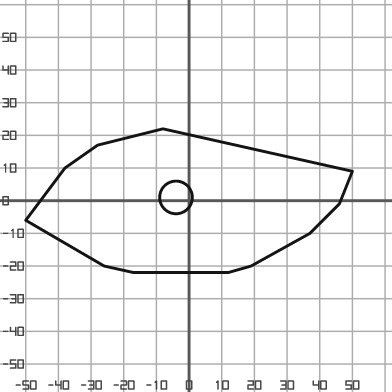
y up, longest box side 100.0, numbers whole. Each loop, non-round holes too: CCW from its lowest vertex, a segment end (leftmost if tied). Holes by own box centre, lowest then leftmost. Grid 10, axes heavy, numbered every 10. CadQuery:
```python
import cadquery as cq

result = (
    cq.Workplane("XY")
    .moveTo(-17.0, -22.0)
    .lineTo(12.0, -22.0)
    .lineTo(19.0, -20.0)
    .lineTo(37.0, -10.0)
    .lineTo(46.0, -1.0)
    .lineTo(50.0, 9.0)
    .lineTo(-8.0, 22.0)
    .lineTo(-28.0, 17.0)
    .lineTo(-38.0, 10.0)
    .lineTo(-50.0, -6.0)
    .lineTo(-26.0, -20.0)
    .close()
    .moveTo(-4.0, 1.0)
    .circle(5.0)
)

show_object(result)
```